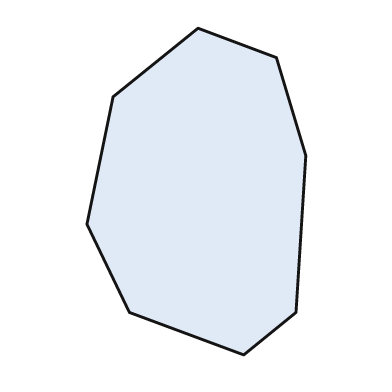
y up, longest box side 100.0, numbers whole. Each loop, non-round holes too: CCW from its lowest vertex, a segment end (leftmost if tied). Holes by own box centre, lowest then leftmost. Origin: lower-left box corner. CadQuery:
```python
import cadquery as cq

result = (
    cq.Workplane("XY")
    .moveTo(48.0, 0.0)
    .lineTo(64.0, 13.0)
    .lineTo(67.0, 61.0)
    .lineTo(58.0, 91.0)
    .lineTo(34.0, 100.0)
    .lineTo(8.0, 79.0)
    .lineTo(0.0, 40.0)
    .lineTo(13.0, 13.0)
    .close()
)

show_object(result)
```